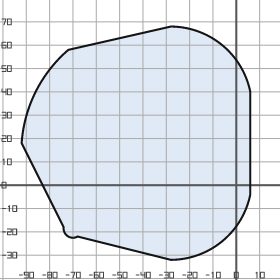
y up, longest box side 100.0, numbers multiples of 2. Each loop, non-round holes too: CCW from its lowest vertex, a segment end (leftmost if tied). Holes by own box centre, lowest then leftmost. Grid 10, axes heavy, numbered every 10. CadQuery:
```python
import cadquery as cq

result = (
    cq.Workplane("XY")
    .moveTo(-28.0, -32.0)
    .threePointArc((-6.0, -24.0), (6.0, -4.0))
    .lineTo(6.0, 40.0)
    .threePointArc((-6.0, 60.0), (-28.0, 68.0))
    .lineTo(-72.0, 58.0)
    .threePointArc((-86.0, 40.0), (-92.0, 18.0))
    .lineTo(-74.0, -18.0)
    .threePointArc((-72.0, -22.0), (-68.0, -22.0))
    .close()
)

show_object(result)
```